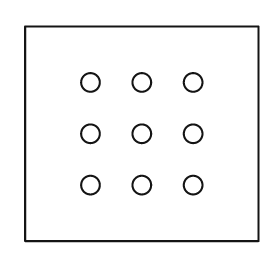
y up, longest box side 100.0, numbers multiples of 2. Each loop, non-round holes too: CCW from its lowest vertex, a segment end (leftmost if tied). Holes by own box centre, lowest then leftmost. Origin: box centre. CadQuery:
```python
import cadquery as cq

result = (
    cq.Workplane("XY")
    .moveTo(-50.0, -46.0)
    .lineTo(50.0, -46.0)
    .lineTo(50.0, 46.0)
    .lineTo(-50.0, 46.0)
    .close()
    .moveTo(-22.0, -22.0)
    .circle(4.0)
    .moveTo(0.0, -22.0)
    .circle(4.0)
    .moveTo(22.0, -22.0)
    .circle(4.0)
    .moveTo(-22.0, 0.0)
    .circle(4.0)
    .moveTo(0.0, 0.0)
    .circle(4.0)
    .moveTo(22.0, 0.0)
    .circle(4.0)
    .moveTo(-22.0, 22.0)
    .circle(4.0)
    .moveTo(0.0, 22.0)
    .circle(4.0)
    .moveTo(22.0, 22.0)
    .circle(4.0)
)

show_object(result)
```